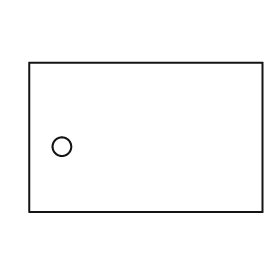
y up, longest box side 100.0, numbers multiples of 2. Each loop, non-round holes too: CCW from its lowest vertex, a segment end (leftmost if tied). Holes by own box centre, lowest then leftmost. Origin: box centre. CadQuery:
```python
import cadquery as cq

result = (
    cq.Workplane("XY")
    .moveTo(-50.0, -32.0)
    .lineTo(50.0, -32.0)
    .lineTo(50.0, 32.0)
    .lineTo(-50.0, 32.0)
    .close()
    .moveTo(-36.0, -4.0)
    .circle(4.0)
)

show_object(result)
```